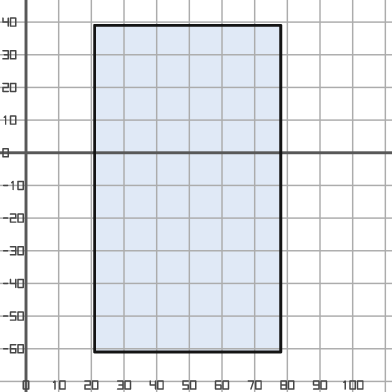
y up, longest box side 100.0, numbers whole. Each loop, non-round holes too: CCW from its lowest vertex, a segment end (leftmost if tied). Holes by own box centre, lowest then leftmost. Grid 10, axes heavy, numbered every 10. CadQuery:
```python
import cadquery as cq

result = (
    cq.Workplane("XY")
    .moveTo(21.0, -61.0)
    .lineTo(78.0, -61.0)
    .lineTo(78.0, 39.0)
    .lineTo(21.0, 39.0)
    .close()
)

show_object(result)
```